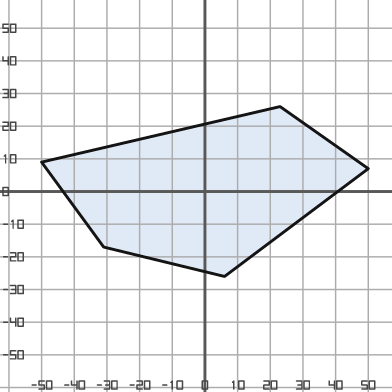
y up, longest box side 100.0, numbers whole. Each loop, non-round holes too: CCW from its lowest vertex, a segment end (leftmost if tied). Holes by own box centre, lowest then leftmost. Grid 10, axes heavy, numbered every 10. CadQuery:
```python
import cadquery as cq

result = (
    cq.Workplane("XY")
    .moveTo(6.0, -26.0)
    .lineTo(50.0, 7.0)
    .lineTo(23.0, 26.0)
    .lineTo(-50.0, 9.0)
    .lineTo(-31.0, -17.0)
    .close()
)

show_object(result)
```